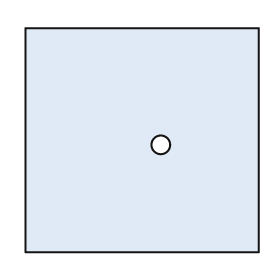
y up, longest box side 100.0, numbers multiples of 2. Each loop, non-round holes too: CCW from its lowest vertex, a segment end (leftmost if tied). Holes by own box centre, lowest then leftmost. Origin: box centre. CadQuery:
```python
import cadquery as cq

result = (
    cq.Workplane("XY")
    .moveTo(-50.0, -48.0)
    .lineTo(50.0, -48.0)
    .lineTo(50.0, 48.0)
    .lineTo(-50.0, 48.0)
    .close()
    .moveTo(8.0, -2.0)
    .circle(4.0)
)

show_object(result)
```